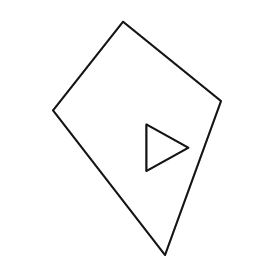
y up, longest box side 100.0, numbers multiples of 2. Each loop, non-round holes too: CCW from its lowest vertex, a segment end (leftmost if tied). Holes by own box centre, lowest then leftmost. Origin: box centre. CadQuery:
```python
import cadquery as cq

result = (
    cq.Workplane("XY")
    .moveTo(12.0, -50.0)
    .lineTo(36.0, 16.0)
    .lineTo(-6.0, 50.0)
    .lineTo(-36.0, 12.0)
    .close()
    .moveTo(4.0, -14.0)
    .lineTo(22.0, -4.0)
    .lineTo(4.0, 6.0)
    .close()
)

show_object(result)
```